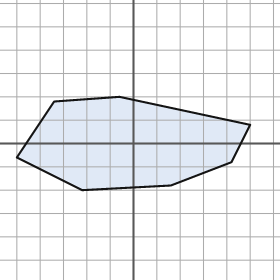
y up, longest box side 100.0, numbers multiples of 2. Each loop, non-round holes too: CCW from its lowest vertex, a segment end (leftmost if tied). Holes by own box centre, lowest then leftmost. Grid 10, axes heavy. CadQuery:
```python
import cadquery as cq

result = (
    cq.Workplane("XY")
    .moveTo(-22.0, -20.0)
    .lineTo(16.0, -18.0)
    .lineTo(42.0, -8.0)
    .lineTo(50.0, 8.0)
    .lineTo(-6.0, 20.0)
    .lineTo(-34.0, 18.0)
    .lineTo(-50.0, -6.0)
    .close()
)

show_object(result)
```